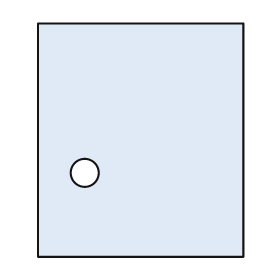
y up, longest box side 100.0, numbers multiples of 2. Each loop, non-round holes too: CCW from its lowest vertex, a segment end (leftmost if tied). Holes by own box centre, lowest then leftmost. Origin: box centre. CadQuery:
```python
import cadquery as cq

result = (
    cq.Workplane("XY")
    .moveTo(-44.0, -50.0)
    .lineTo(44.0, -50.0)
    .lineTo(44.0, 50.0)
    .lineTo(-44.0, 50.0)
    .close()
    .moveTo(-24.0, -14.0)
    .circle(6.0)
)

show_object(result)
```